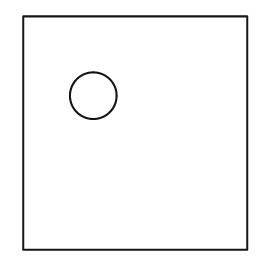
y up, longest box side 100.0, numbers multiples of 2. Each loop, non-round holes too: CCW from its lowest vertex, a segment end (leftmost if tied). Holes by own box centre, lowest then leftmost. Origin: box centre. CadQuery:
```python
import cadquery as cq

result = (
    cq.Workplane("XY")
    .moveTo(-48.0, -50.0)
    .lineTo(48.0, -50.0)
    .lineTo(48.0, 50.0)
    .lineTo(-48.0, 50.0)
    .close()
    .moveTo(-18.0, 16.0)
    .circle(10.0)
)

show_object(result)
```